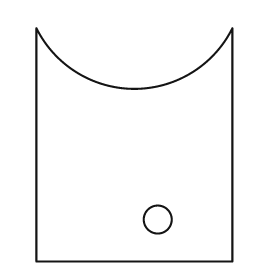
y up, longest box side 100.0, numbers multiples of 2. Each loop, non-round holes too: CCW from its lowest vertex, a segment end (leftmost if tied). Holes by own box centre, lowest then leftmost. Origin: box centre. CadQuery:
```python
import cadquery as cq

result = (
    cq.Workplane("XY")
    .moveTo(-42.0, -50.0)
    .lineTo(42.0, -50.0)
    .lineTo(42.0, 50.0)
    .threePointArc((0.0, 24.0), (-42.0, 50.0))
    .close()
    .moveTo(10.0, -32.0)
    .circle(6.0)
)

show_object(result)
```